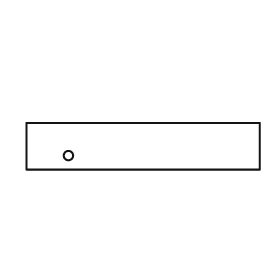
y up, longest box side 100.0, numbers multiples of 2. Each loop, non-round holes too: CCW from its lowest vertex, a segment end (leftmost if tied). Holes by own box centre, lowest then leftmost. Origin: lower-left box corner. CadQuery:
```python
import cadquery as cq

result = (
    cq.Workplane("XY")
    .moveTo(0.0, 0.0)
    .lineTo(100.0, 0.0)
    .lineTo(100.0, 20.0)
    .lineTo(0.0, 20.0)
    .close()
    .moveTo(18.0, 6.0)
    .circle(2.0)
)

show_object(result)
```